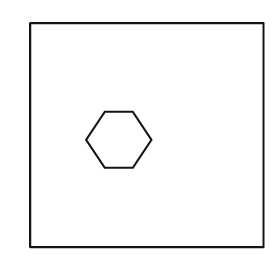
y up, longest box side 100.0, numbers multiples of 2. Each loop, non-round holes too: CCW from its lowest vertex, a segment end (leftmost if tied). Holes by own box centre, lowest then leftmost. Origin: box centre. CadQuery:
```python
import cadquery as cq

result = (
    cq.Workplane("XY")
    .moveTo(-50.0, -48.0)
    .lineTo(50.0, -48.0)
    .lineTo(50.0, 48.0)
    .lineTo(-50.0, 48.0)
    .close()
    .moveTo(-18.0, -14.0)
    .lineTo(-6.0, -14.0)
    .lineTo(2.0, -2.0)
    .lineTo(-6.0, 10.0)
    .lineTo(-18.0, 10.0)
    .lineTo(-26.0, -2.0)
    .close()
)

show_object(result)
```